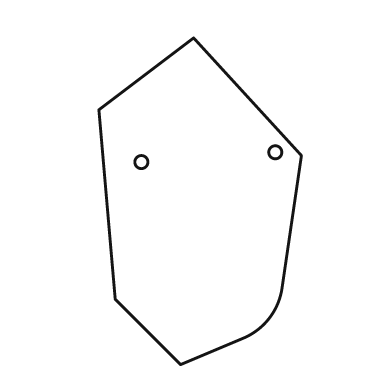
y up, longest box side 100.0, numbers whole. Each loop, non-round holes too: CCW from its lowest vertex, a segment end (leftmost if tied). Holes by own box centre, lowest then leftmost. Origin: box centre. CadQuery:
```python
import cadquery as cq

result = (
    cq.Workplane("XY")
    .moveTo(-6.0, -50.0)
    .lineTo(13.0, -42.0)
    .threePointArc((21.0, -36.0), (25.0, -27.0))
    .lineTo(31.0, 14.0)
    .lineTo(-2.0, 50.0)
    .lineTo(-31.0, 28.0)
    .lineTo(-26.0, -30.0)
    .close()
    .moveTo(-18.0, 12.0)
    .circle(2.0)
    .moveTo(23.0, 15.0)
    .circle(2.0)
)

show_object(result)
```